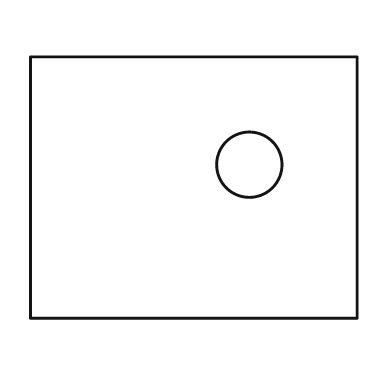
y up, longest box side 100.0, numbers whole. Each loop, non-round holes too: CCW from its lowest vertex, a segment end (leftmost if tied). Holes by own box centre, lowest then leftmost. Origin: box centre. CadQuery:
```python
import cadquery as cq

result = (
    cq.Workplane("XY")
    .moveTo(-50.0, -40.0)
    .lineTo(50.0, -40.0)
    .lineTo(50.0, 40.0)
    .lineTo(-50.0, 40.0)
    .close()
    .moveTo(17.0, 7.0)
    .circle(10.0)
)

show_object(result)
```